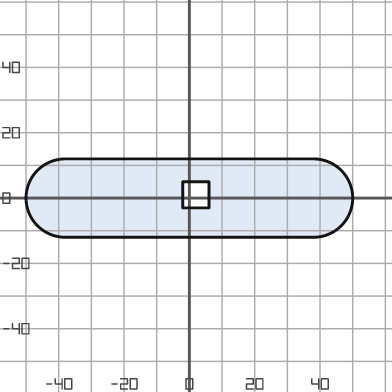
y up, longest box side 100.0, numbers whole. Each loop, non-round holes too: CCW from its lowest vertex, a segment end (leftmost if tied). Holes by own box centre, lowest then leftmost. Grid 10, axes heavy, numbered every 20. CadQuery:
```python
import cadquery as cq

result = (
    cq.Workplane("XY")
    .moveTo(-38.0, -12.0)
    .lineTo(38.0, -12.0)
    .threePointArc((50.0, 0.0), (38.0, 12.0))
    .lineTo(-38.0, 12.0)
    .threePointArc((-50.0, 0.0), (-38.0, -12.0))
    .close()
    .moveTo(-2.0, -3.0)
    .lineTo(6.0, -3.0)
    .lineTo(6.0, 5.0)
    .lineTo(-2.0, 5.0)
    .close()
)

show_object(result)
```